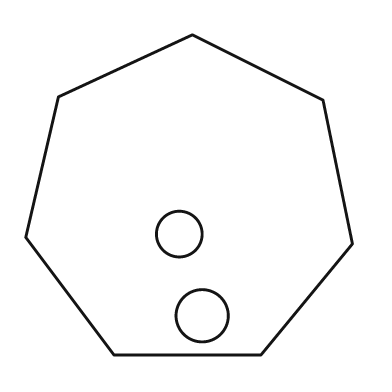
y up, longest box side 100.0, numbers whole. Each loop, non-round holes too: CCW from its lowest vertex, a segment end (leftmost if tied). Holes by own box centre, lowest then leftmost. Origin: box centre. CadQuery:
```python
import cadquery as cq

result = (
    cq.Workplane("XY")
    .moveTo(-23.0, -49.0)
    .lineTo(22.0, -49.0)
    .lineTo(50.0, -15.0)
    .lineTo(41.0, 29.0)
    .lineTo(1.0, 49.0)
    .lineTo(-40.0, 30.0)
    .lineTo(-50.0, -13.0)
    .close()
    .moveTo(4.0, -37.0)
    .circle(8.0)
    .moveTo(-3.0, -12.0)
    .circle(7.0)
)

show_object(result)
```